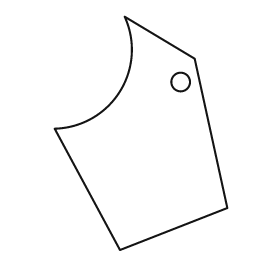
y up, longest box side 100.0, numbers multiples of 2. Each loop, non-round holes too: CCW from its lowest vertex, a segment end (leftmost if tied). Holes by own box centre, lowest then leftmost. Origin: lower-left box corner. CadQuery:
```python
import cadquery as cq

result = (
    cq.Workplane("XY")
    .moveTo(28.0, 0.0)
    .lineTo(74.0, 18.0)
    .lineTo(60.0, 82.0)
    .lineTo(30.0, 100.0)
    .threePointArc((28.0, 68.0), (0.0, 52.0))
    .close()
    .moveTo(54.0, 72.0)
    .circle(4.0)
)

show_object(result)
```